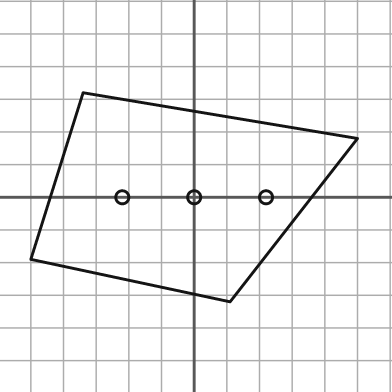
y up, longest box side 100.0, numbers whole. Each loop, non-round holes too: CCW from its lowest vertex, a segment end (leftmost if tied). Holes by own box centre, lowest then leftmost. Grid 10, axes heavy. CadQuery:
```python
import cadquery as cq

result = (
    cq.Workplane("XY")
    .moveTo(11.0, -32.0)
    .lineTo(50.0, 18.0)
    .lineTo(-34.0, 32.0)
    .lineTo(-50.0, -19.0)
    .close()
    .moveTo(-22.0, 0.0)
    .circle(2.0)
    .moveTo(0.0, 0.0)
    .circle(2.0)
    .moveTo(22.0, 0.0)
    .circle(2.0)
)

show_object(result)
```